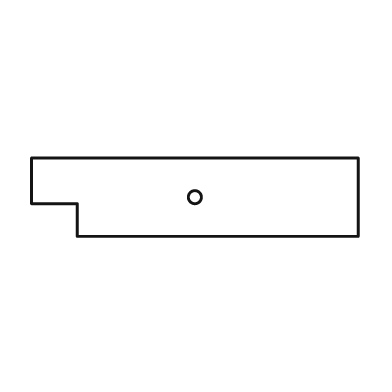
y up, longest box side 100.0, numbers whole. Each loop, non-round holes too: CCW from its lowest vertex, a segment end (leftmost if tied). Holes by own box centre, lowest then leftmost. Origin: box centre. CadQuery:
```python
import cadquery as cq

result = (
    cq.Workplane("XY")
    .moveTo(-36.0, -12.0)
    .lineTo(50.0, -12.0)
    .lineTo(50.0, 12.0)
    .lineTo(-50.0, 12.0)
    .lineTo(-50.0, -2.0)
    .lineTo(-36.0, -2.0)
    .close()
    .moveTo(0.0, 0.0)
    .circle(2.0)
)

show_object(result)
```